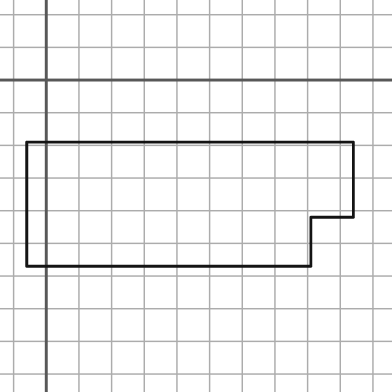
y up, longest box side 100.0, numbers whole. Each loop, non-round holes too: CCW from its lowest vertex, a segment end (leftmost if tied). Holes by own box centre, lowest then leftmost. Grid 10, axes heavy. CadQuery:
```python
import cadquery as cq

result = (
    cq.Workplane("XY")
    .moveTo(-6.0, -57.0)
    .lineTo(81.0, -57.0)
    .lineTo(81.0, -42.0)
    .lineTo(94.0, -42.0)
    .lineTo(94.0, -19.0)
    .lineTo(-6.0, -19.0)
    .close()
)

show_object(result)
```